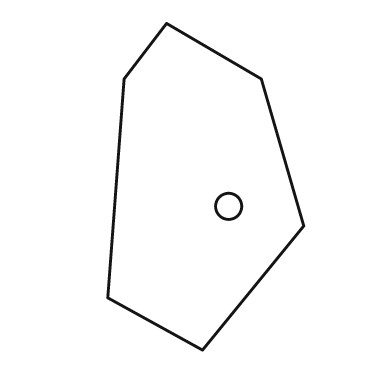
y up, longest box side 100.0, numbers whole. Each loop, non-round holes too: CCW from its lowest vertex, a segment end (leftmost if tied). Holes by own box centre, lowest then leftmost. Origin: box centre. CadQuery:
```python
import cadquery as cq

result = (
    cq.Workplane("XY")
    .moveTo(-1.0, -50.0)
    .lineTo(30.0, -12.0)
    .lineTo(17.0, 33.0)
    .lineTo(-12.0, 50.0)
    .lineTo(-25.0, 33.0)
    .lineTo(-30.0, -34.0)
    .close()
    .moveTo(7.0, -6.0)
    .circle(4.0)
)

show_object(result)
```